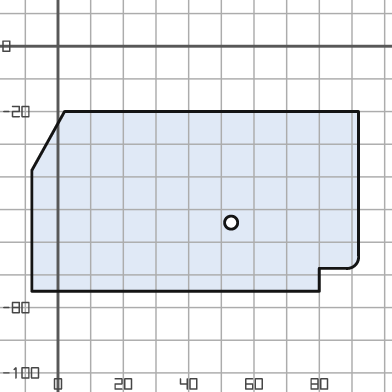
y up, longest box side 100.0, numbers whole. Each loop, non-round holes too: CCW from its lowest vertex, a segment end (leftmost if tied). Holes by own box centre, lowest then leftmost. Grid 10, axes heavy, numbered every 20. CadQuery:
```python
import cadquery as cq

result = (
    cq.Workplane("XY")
    .moveTo(-8.0, -75.0)
    .lineTo(80.0, -75.0)
    .lineTo(80.0, -68.0)
    .lineTo(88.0, -68.0)
    .threePointArc((91.0, -67.0), (92.0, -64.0))
    .lineTo(92.0, -20.0)
    .lineTo(2.0, -20.0)
    .lineTo(-8.0, -38.0)
    .close()
    .moveTo(53.0, -54.0)
    .circle(2.0)
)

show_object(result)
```